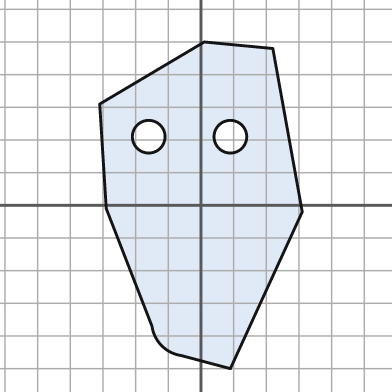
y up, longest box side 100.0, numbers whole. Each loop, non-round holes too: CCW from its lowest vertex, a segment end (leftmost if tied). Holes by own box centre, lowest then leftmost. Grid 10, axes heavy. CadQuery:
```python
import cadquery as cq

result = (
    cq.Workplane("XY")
    .moveTo(9.0, -50.0)
    .lineTo(31.0, -2.0)
    .lineTo(22.0, 48.0)
    .lineTo(1.0, 50.0)
    .lineTo(-31.0, 31.0)
    .lineTo(-29.0, -1.0)
    .lineTo(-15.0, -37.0)
    .threePointArc((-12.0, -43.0), (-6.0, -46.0))
    .close()
    .moveTo(-16.0, 21.0)
    .circle(5.0)
    .moveTo(9.0, 21.0)
    .circle(5.0)
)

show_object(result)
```